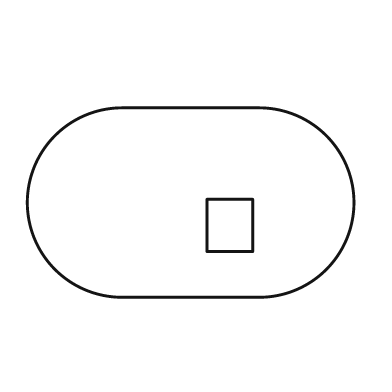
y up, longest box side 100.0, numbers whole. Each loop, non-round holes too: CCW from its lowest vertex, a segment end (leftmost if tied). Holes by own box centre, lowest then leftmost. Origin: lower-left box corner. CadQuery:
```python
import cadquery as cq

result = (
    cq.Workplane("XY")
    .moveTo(29.0, 0.0)
    .lineTo(71.0, 0.0)
    .threePointArc((100.0, 29.0), (71.0, 58.0))
    .lineTo(29.0, 58.0)
    .threePointArc((0.0, 29.0), (29.0, 0.0))
    .close()
    .moveTo(55.0, 14.0)
    .lineTo(69.0, 14.0)
    .lineTo(69.0, 30.0)
    .lineTo(55.0, 30.0)
    .close()
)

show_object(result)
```